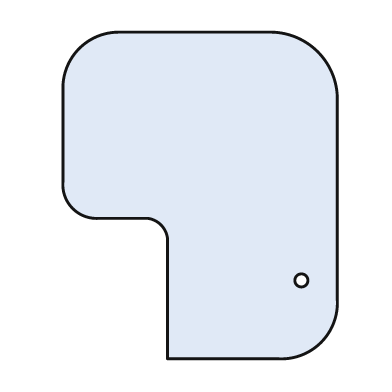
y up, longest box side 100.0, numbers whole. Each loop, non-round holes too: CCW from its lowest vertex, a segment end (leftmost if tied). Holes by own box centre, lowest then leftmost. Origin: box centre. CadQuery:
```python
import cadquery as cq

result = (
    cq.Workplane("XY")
    .moveTo(-10.0, -50.0)
    .lineTo(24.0, -50.0)
    .threePointArc((37.0, -45.0), (42.0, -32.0))
    .lineTo(42.0, 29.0)
    .threePointArc((36.0, 44.0), (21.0, 50.0))
    .lineTo(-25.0, 50.0)
    .threePointArc((-37.0, 45.0), (-42.0, 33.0))
    .lineTo(-42.0, 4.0)
    .threePointArc((-39.0, -4.0), (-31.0, -7.0))
    .lineTo(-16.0, -7.0)
    .threePointArc((-12.0, -9.0), (-10.0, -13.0))
    .close()
    .moveTo(31.0, -26.0)
    .circle(2.0)
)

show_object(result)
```